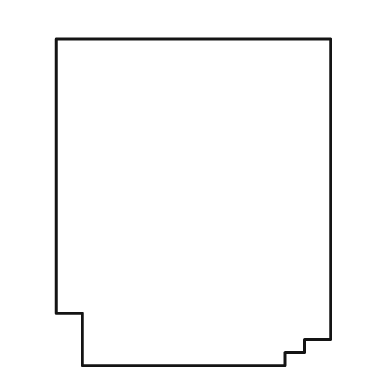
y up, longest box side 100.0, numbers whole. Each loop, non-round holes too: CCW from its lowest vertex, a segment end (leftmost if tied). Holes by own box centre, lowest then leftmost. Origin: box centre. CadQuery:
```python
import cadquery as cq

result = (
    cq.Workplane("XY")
    .moveTo(-34.0, -50.0)
    .lineTo(28.0, -50.0)
    .lineTo(28.0, -46.0)
    .lineTo(34.0, -46.0)
    .lineTo(34.0, -42.0)
    .lineTo(42.0, -42.0)
    .lineTo(42.0, 50.0)
    .lineTo(-42.0, 50.0)
    .lineTo(-42.0, -34.0)
    .lineTo(-34.0, -34.0)
    .close()
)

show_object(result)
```